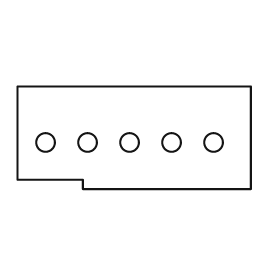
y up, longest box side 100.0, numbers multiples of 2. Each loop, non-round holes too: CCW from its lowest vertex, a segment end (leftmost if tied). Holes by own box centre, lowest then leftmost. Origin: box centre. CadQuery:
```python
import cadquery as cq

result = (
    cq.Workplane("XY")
    .moveTo(-22.0, -22.0)
    .lineTo(50.0, -22.0)
    .lineTo(50.0, 22.0)
    .lineTo(-50.0, 22.0)
    .lineTo(-50.0, -18.0)
    .lineTo(-22.0, -18.0)
    .close()
    .moveTo(-38.0, -2.0)
    .circle(4.0)
    .moveTo(-20.0, -2.0)
    .circle(4.0)
    .moveTo(-2.0, -2.0)
    .circle(4.0)
    .moveTo(16.0, -2.0)
    .circle(4.0)
    .moveTo(34.0, -2.0)
    .circle(4.0)
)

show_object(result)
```